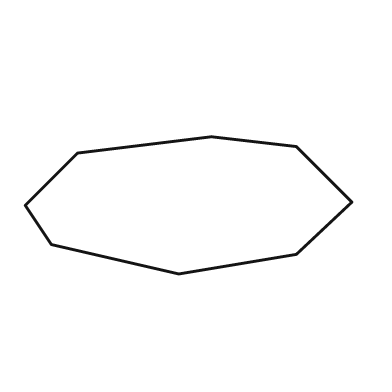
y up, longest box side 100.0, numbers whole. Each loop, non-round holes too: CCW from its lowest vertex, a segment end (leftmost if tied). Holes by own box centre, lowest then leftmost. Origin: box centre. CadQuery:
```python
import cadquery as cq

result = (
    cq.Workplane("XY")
    .moveTo(-3.0, -21.0)
    .lineTo(33.0, -15.0)
    .lineTo(50.0, 1.0)
    .lineTo(33.0, 18.0)
    .lineTo(7.0, 21.0)
    .lineTo(-34.0, 16.0)
    .lineTo(-50.0, 0.0)
    .lineTo(-42.0, -12.0)
    .close()
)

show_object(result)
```